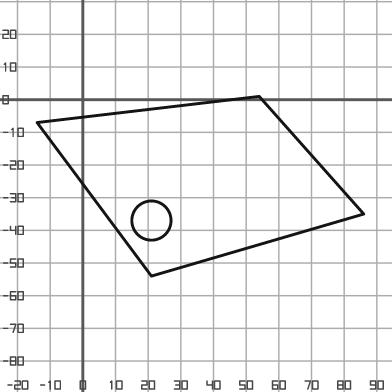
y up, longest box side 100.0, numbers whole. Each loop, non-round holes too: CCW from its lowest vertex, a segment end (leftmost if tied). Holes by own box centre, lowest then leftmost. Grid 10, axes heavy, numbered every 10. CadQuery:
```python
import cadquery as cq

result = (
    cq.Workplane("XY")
    .moveTo(21.0, -54.0)
    .lineTo(86.0, -35.0)
    .lineTo(54.0, 1.0)
    .lineTo(-14.0, -7.0)
    .close()
    .moveTo(21.0, -37.0)
    .circle(6.0)
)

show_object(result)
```